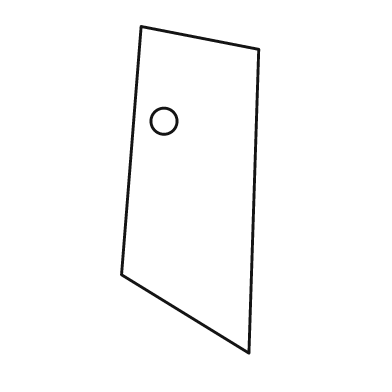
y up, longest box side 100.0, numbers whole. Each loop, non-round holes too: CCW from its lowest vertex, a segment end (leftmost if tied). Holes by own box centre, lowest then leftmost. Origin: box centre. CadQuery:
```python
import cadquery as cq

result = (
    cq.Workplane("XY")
    .moveTo(18.0, -50.0)
    .lineTo(21.0, 43.0)
    .lineTo(-15.0, 50.0)
    .lineTo(-21.0, -26.0)
    .close()
    .moveTo(-8.0, 21.0)
    .circle(4.0)
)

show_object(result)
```